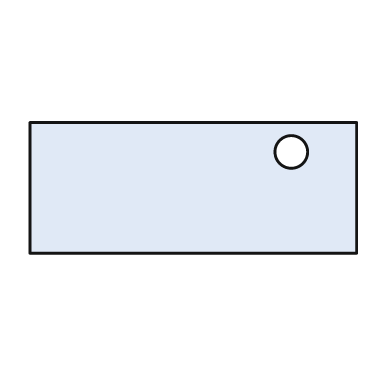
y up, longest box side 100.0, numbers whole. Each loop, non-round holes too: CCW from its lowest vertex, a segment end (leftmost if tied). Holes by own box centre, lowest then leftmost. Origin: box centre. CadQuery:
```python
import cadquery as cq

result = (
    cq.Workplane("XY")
    .moveTo(-50.0, -20.0)
    .lineTo(50.0, -20.0)
    .lineTo(50.0, 20.0)
    .lineTo(-50.0, 20.0)
    .close()
    .moveTo(30.0, 11.0)
    .circle(5.0)
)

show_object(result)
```